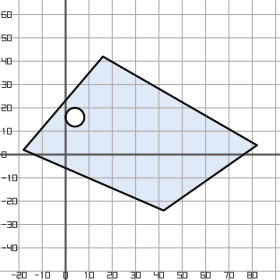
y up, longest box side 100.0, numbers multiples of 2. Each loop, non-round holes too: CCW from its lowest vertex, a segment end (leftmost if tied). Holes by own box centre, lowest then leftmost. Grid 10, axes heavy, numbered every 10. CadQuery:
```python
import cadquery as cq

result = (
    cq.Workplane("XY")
    .moveTo(42.0, -24.0)
    .lineTo(82.0, 4.0)
    .lineTo(16.0, 42.0)
    .lineTo(-18.0, 2.0)
    .close()
    .moveTo(4.0, 16.0)
    .circle(4.0)
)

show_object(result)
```